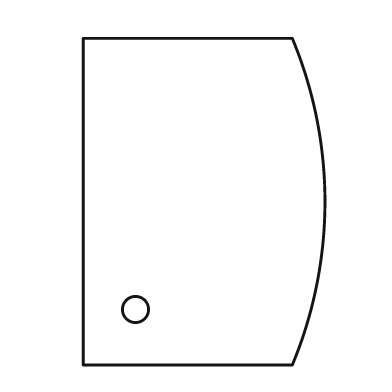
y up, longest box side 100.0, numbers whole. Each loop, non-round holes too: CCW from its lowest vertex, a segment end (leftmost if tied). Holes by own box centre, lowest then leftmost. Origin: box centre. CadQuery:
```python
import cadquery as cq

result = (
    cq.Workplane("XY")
    .moveTo(-37.0, -50.0)
    .lineTo(27.0, -50.0)
    .threePointArc((37.0, 0.0), (27.0, 50.0))
    .lineTo(-37.0, 50.0)
    .close()
    .moveTo(-21.0, -33.0)
    .circle(4.0)
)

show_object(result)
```